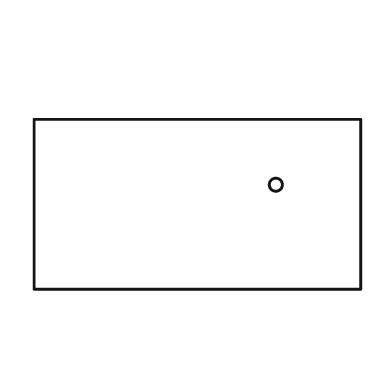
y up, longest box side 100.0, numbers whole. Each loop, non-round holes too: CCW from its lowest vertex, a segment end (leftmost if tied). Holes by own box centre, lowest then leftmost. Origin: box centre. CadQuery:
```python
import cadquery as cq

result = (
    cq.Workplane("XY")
    .moveTo(-50.0, -26.0)
    .lineTo(50.0, -26.0)
    .lineTo(50.0, 26.0)
    .lineTo(-50.0, 26.0)
    .close()
    .moveTo(24.0, 6.0)
    .circle(2.0)
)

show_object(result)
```